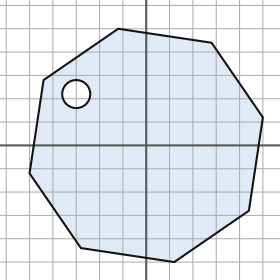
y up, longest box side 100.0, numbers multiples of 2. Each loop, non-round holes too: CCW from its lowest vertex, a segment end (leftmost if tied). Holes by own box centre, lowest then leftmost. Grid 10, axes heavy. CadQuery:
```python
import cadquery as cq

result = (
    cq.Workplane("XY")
    .moveTo(12.0, -50.0)
    .lineTo(44.0, -28.0)
    .lineTo(50.0, 12.0)
    .lineTo(28.0, 44.0)
    .lineTo(-12.0, 50.0)
    .lineTo(-44.0, 28.0)
    .lineTo(-50.0, -12.0)
    .lineTo(-28.0, -44.0)
    .close()
    .moveTo(-30.0, 22.0)
    .circle(6.0)
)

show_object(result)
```